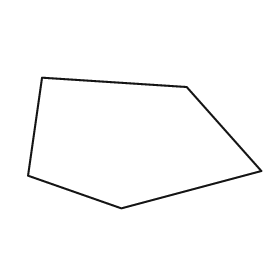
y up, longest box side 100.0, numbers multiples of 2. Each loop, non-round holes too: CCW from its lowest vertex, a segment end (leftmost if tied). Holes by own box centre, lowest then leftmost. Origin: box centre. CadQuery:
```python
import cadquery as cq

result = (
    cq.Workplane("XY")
    .moveTo(-10.0, -28.0)
    .lineTo(50.0, -12.0)
    .lineTo(18.0, 24.0)
    .lineTo(-44.0, 28.0)
    .lineTo(-50.0, -14.0)
    .close()
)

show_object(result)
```